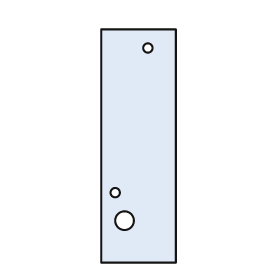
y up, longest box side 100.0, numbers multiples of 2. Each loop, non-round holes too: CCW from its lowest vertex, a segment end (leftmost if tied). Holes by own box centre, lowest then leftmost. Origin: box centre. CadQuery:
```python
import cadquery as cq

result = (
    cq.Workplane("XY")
    .moveTo(-16.0, -50.0)
    .lineTo(16.0, -50.0)
    .lineTo(16.0, 50.0)
    .lineTo(-16.0, 50.0)
    .close()
    .moveTo(-6.0, -32.0)
    .circle(4.0)
    .moveTo(-10.0, -20.0)
    .circle(2.0)
    .moveTo(4.0, 42.0)
    .circle(2.0)
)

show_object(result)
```